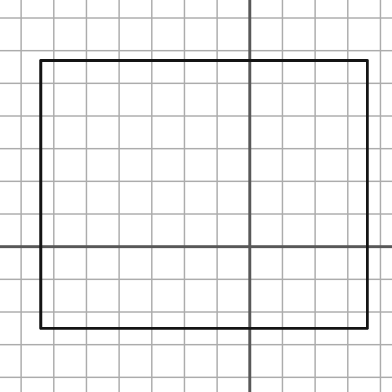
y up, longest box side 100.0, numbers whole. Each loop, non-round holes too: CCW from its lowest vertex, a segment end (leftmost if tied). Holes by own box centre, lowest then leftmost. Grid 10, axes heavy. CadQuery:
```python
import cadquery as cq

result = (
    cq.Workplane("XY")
    .moveTo(-64.0, -25.0)
    .lineTo(36.0, -25.0)
    .lineTo(36.0, 57.0)
    .lineTo(-64.0, 57.0)
    .close()
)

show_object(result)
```